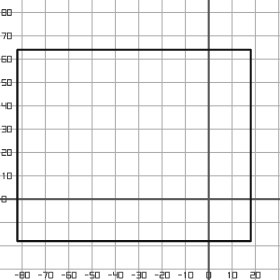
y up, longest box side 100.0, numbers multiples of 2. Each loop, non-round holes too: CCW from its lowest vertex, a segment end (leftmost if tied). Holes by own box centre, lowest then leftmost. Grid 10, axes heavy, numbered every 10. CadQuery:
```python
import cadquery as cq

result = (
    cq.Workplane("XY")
    .moveTo(-82.0, -18.0)
    .lineTo(18.0, -18.0)
    .lineTo(18.0, 64.0)
    .lineTo(-82.0, 64.0)
    .close()
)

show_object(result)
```